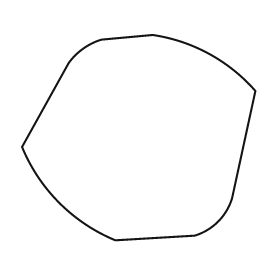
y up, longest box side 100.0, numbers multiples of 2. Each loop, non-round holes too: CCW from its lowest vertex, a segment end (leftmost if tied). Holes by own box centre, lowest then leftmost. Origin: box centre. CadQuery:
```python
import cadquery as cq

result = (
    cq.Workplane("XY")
    .moveTo(-10.0, -44.0)
    .lineTo(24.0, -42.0)
    .threePointArc((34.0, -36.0), (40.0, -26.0))
    .lineTo(50.0, 20.0)
    .threePointArc((30.0, 36.0), (6.0, 44.0))
    .lineTo(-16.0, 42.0)
    .threePointArc((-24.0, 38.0), (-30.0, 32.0))
    .lineTo(-50.0, -4.0)
    .threePointArc((-34.0, -28.0), (-10.0, -44.0))
    .close()
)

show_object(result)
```